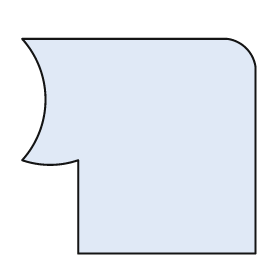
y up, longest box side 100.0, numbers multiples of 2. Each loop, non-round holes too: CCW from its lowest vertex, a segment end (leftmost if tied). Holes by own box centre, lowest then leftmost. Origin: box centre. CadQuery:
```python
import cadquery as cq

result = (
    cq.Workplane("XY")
    .moveTo(-26.0, -46.0)
    .lineTo(50.0, -46.0)
    .lineTo(50.0, 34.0)
    .threePointArc((46.0, 42.0), (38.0, 46.0))
    .lineTo(-50.0, 46.0)
    .threePointArc((-40.0, 20.0), (-50.0, -6.0))
    .threePointArc((-38.0, -8.0), (-26.0, -6.0))
    .close()
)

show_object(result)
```